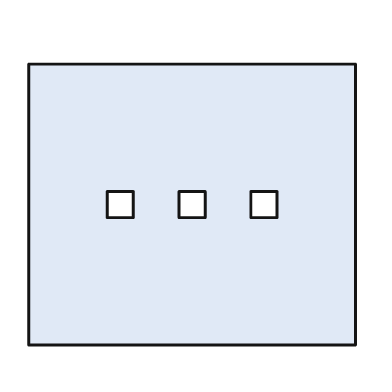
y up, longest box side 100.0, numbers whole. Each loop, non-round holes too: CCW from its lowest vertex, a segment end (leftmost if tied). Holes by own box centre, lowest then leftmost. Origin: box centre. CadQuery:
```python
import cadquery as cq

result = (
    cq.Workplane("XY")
    .moveTo(-50.0, -43.0)
    .lineTo(50.0, -43.0)
    .lineTo(50.0, 43.0)
    .lineTo(-50.0, 43.0)
    .close()
    .moveTo(-26.0, -4.0)
    .lineTo(-18.0, -4.0)
    .lineTo(-18.0, 4.0)
    .lineTo(-26.0, 4.0)
    .close()
    .moveTo(-4.0, -4.0)
    .lineTo(4.0, -4.0)
    .lineTo(4.0, 4.0)
    .lineTo(-4.0, 4.0)
    .close()
    .moveTo(18.0, -4.0)
    .lineTo(26.0, -4.0)
    .lineTo(26.0, 4.0)
    .lineTo(18.0, 4.0)
    .close()
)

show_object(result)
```